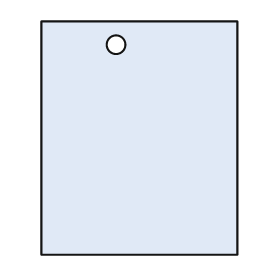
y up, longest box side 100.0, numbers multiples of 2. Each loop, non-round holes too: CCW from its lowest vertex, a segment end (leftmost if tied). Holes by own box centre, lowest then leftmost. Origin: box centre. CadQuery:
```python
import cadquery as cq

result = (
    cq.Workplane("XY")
    .moveTo(-42.0, -50.0)
    .lineTo(42.0, -50.0)
    .lineTo(42.0, 50.0)
    .lineTo(-42.0, 50.0)
    .close()
    .moveTo(-10.0, 40.0)
    .circle(4.0)
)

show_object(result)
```